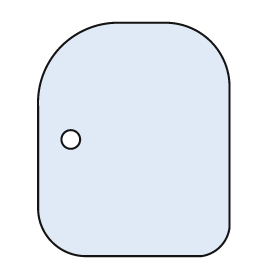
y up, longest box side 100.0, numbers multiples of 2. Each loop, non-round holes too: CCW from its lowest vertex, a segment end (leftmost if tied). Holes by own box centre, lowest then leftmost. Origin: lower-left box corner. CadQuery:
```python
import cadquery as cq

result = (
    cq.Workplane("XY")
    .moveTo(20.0, 0.0)
    .lineTo(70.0, 0.0)
    .threePointArc((78.0, 4.0), (82.0, 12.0))
    .lineTo(82.0, 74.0)
    .threePointArc((74.0, 92.0), (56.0, 100.0))
    .lineTo(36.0, 100.0)
    .threePointArc((10.0, 90.0), (0.0, 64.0))
    .lineTo(0.0, 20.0)
    .threePointArc((6.0, 6.0), (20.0, 0.0))
    .close()
    .moveTo(14.0, 50.0)
    .circle(4.0)
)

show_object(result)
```